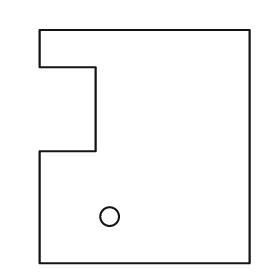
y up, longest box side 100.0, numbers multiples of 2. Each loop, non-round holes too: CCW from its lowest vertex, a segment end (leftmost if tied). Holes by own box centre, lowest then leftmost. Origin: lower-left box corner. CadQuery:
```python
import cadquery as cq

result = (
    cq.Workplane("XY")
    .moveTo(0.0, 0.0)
    .lineTo(90.0, 0.0)
    .lineTo(90.0, 100.0)
    .lineTo(0.0, 100.0)
    .lineTo(0.0, 84.0)
    .lineTo(24.0, 84.0)
    .lineTo(24.0, 48.0)
    .lineTo(0.0, 48.0)
    .close()
    .moveTo(30.0, 20.0)
    .circle(4.0)
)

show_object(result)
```